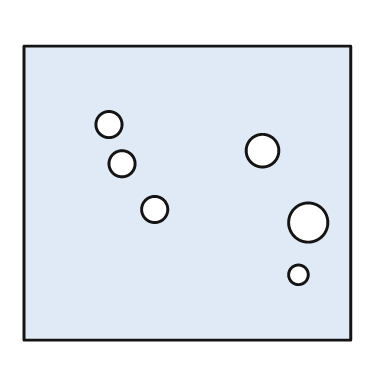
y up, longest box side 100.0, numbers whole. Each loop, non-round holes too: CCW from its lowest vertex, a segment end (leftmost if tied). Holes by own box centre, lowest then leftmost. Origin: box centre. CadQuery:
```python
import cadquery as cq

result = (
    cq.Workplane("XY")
    .moveTo(-50.0, -45.0)
    .lineTo(50.0, -45.0)
    .lineTo(50.0, 45.0)
    .lineTo(-50.0, 45.0)
    .close()
    .moveTo(34.0, -25.0)
    .circle(3.0)
    .moveTo(37.0, -9.0)
    .circle(6.0)
    .moveTo(-10.0, -5.0)
    .circle(4.0)
    .moveTo(-20.0, 9.0)
    .circle(4.0)
    .moveTo(23.0, 13.0)
    .circle(5.0)
    .moveTo(-24.0, 21.0)
    .circle(4.0)
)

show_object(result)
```